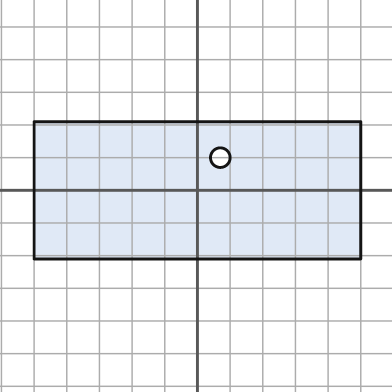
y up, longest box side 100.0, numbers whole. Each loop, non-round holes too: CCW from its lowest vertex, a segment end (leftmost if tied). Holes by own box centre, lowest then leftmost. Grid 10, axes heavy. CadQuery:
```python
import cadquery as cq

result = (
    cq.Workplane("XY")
    .moveTo(-50.0, -21.0)
    .lineTo(50.0, -21.0)
    .lineTo(50.0, 21.0)
    .lineTo(-50.0, 21.0)
    .close()
    .moveTo(7.0, 10.0)
    .circle(3.0)
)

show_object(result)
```